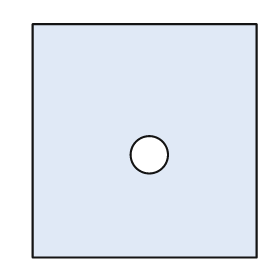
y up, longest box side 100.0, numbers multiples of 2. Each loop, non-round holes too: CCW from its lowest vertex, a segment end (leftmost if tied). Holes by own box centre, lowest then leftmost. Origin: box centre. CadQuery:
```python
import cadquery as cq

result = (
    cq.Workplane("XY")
    .moveTo(-48.0, -50.0)
    .lineTo(48.0, -50.0)
    .lineTo(48.0, 50.0)
    .lineTo(-48.0, 50.0)
    .close()
    .moveTo(2.0, -6.0)
    .circle(8.0)
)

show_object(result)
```